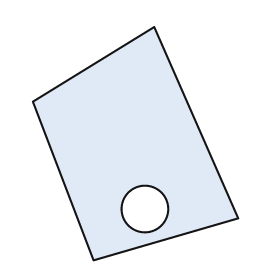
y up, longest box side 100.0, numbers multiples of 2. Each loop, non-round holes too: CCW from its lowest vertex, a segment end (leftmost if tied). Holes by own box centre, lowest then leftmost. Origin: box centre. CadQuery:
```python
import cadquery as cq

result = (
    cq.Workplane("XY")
    .moveTo(-18.0, -50.0)
    .lineTo(44.0, -32.0)
    .lineTo(8.0, 50.0)
    .lineTo(-44.0, 18.0)
    .close()
    .moveTo(4.0, -28.0)
    .circle(10.0)
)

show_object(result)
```